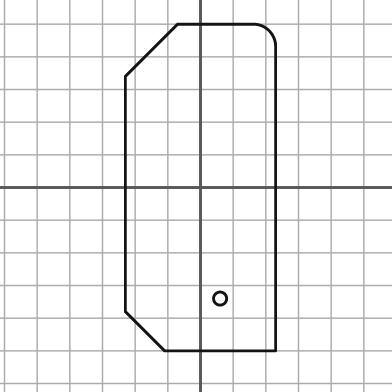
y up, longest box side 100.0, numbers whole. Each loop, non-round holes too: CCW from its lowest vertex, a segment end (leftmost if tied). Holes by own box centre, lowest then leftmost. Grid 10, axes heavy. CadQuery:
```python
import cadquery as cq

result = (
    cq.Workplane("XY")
    .moveTo(-11.0, -50.0)
    .lineTo(23.0, -50.0)
    .lineTo(23.0, 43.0)
    .threePointArc((21.0, 48.0), (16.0, 50.0))
    .lineTo(-7.0, 50.0)
    .lineTo(-23.0, 34.0)
    .lineTo(-23.0, -38.0)
    .close()
    .moveTo(6.0, -34.0)
    .circle(2.0)
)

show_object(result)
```